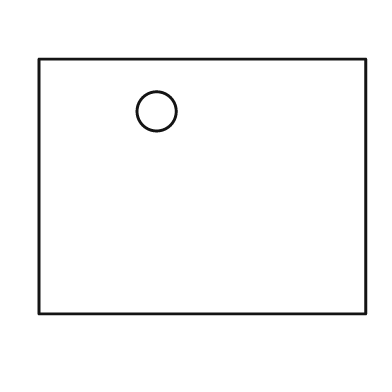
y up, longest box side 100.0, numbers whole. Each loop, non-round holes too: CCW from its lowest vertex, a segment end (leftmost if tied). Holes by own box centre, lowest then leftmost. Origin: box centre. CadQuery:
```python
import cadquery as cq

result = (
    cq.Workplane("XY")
    .moveTo(-50.0, -39.0)
    .lineTo(50.0, -39.0)
    .lineTo(50.0, 39.0)
    .lineTo(-50.0, 39.0)
    .close()
    .moveTo(-14.0, 23.0)
    .circle(6.0)
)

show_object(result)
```